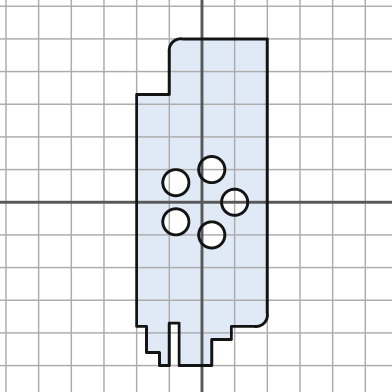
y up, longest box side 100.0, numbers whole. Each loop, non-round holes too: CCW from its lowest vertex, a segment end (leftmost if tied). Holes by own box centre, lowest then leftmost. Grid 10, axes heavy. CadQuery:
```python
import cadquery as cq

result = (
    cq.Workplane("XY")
    .moveTo(-13.0, -50.0)
    .lineTo(-10.0, -50.0)
    .lineTo(-10.0, -37.0)
    .lineTo(-7.0, -37.0)
    .lineTo(-7.0, -50.0)
    .lineTo(3.0, -50.0)
    .lineTo(3.0, -42.0)
    .lineTo(9.0, -42.0)
    .lineTo(9.0, -38.0)
    .lineTo(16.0, -38.0)
    .threePointArc((19.0, -37.0), (20.0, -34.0))
    .lineTo(20.0, 50.0)
    .lineTo(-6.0, 50.0)
    .threePointArc((-9.0, 49.0), (-10.0, 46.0))
    .lineTo(-10.0, 33.0)
    .lineTo(-20.0, 33.0)
    .lineTo(-20.0, -38.0)
    .lineTo(-17.0, -38.0)
    .lineTo(-17.0, -46.0)
    .lineTo(-13.0, -46.0)
    .close()
    .moveTo(3.0, -10.0)
    .circle(4.0)
    .moveTo(-8.0, -6.0)
    .circle(4.0)
    .moveTo(10.0, 0.0)
    .circle(4.0)
    .moveTo(-8.0, 6.0)
    .circle(4.0)
    .moveTo(3.0, 10.0)
    .circle(4.0)
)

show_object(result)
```